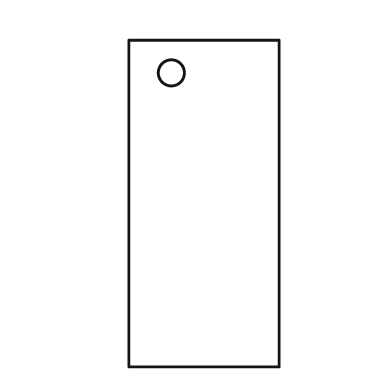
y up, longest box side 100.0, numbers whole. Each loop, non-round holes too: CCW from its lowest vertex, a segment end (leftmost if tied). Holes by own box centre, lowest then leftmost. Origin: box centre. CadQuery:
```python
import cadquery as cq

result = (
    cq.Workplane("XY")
    .moveTo(-23.0, -50.0)
    .lineTo(23.0, -50.0)
    .lineTo(23.0, 50.0)
    .lineTo(-23.0, 50.0)
    .close()
    .moveTo(-10.0, 40.0)
    .circle(4.0)
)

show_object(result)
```